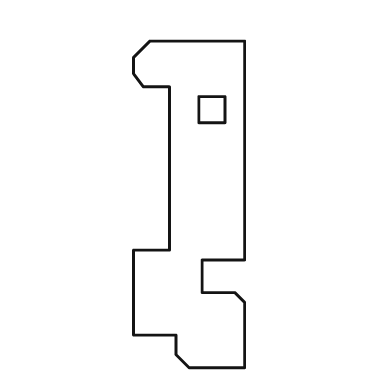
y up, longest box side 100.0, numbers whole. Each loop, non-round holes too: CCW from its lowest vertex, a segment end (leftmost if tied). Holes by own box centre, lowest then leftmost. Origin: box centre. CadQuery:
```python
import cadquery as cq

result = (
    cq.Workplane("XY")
    .moveTo(0.0, -50.0)
    .lineTo(17.0, -50.0)
    .lineTo(17.0, -30.0)
    .lineTo(14.0, -27.0)
    .lineTo(4.0, -27.0)
    .lineTo(4.0, -17.0)
    .lineTo(17.0, -17.0)
    .lineTo(17.0, 50.0)
    .lineTo(-12.0, 50.0)
    .lineTo(-17.0, 45.0)
    .lineTo(-17.0, 40.0)
    .lineTo(-14.0, 36.0)
    .lineTo(-6.0, 36.0)
    .lineTo(-6.0, -14.0)
    .lineTo(-17.0, -14.0)
    .lineTo(-17.0, -40.0)
    .lineTo(-4.0, -40.0)
    .lineTo(-4.0, -46.0)
    .close()
    .moveTo(3.0, 25.0)
    .lineTo(11.0, 25.0)
    .lineTo(11.0, 33.0)
    .lineTo(3.0, 33.0)
    .close()
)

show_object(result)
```